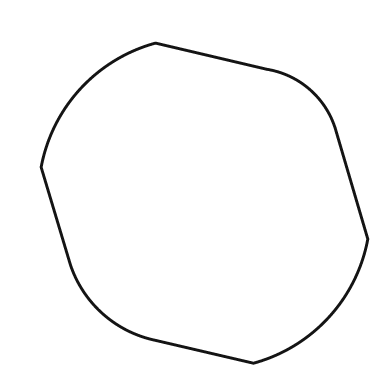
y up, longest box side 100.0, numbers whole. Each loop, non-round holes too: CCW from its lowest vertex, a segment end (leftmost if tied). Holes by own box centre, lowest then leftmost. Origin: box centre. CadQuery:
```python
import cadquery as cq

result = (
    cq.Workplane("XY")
    .moveTo(15.0, -49.0)
    .threePointArc((38.0, -35.0), (50.0, -11.0))
    .lineTo(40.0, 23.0)
    .threePointArc((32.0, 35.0), (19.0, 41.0))
    .lineTo(-15.0, 49.0)
    .threePointArc((-38.0, 35.0), (-50.0, 11.0))
    .lineTo(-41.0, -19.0)
    .threePointArc((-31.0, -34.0), (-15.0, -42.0))
    .close()
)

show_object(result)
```